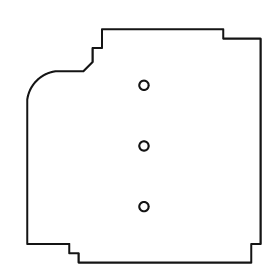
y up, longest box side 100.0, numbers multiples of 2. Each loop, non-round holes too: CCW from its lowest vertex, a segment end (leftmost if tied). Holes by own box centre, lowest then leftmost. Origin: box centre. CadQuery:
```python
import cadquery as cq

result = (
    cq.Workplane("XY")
    .moveTo(-28.0, -50.0)
    .lineTo(46.0, -50.0)
    .lineTo(46.0, -42.0)
    .lineTo(50.0, -42.0)
    .lineTo(50.0, 46.0)
    .lineTo(34.0, 46.0)
    .lineTo(34.0, 50.0)
    .lineTo(-18.0, 50.0)
    .lineTo(-18.0, 42.0)
    .lineTo(-22.0, 42.0)
    .lineTo(-22.0, 36.0)
    .lineTo(-26.0, 32.0)
    .lineTo(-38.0, 32.0)
    .threePointArc((-46.0, 28.0), (-50.0, 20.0))
    .lineTo(-50.0, -42.0)
    .lineTo(-32.0, -42.0)
    .lineTo(-32.0, -46.0)
    .lineTo(-28.0, -46.0)
    .close()
    .moveTo(0.0, -26.0)
    .circle(2.0)
    .moveTo(0.0, 0.0)
    .circle(2.0)
    .moveTo(0.0, 26.0)
    .circle(2.0)
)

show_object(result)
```